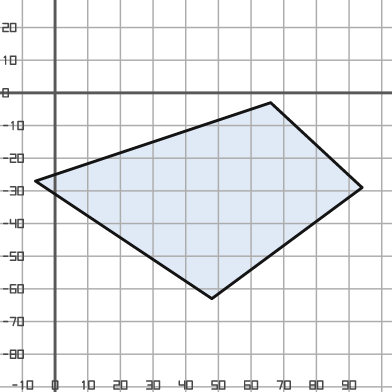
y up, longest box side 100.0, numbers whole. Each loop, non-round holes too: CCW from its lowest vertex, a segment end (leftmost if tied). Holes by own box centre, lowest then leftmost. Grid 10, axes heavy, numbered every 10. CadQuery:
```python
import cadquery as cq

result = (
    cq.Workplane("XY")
    .moveTo(48.0, -63.0)
    .lineTo(94.0, -29.0)
    .lineTo(66.0, -3.0)
    .lineTo(-6.0, -27.0)
    .close()
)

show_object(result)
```